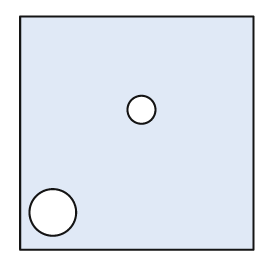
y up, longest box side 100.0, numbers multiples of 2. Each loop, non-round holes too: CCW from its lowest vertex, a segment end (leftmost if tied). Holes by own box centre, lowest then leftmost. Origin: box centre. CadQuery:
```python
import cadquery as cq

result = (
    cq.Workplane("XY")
    .moveTo(-50.0, -50.0)
    .lineTo(50.0, -50.0)
    .lineTo(50.0, 50.0)
    .lineTo(-50.0, 50.0)
    .close()
    .moveTo(-36.0, -34.0)
    .circle(10.0)
    .moveTo(2.0, 10.0)
    .circle(6.0)
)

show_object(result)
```